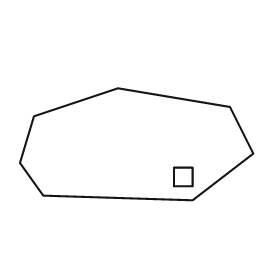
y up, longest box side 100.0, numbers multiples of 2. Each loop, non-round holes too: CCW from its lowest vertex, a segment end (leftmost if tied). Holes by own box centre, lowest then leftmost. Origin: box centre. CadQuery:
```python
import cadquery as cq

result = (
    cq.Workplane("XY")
    .moveTo(24.0, -24.0)
    .lineTo(50.0, -4.0)
    .lineTo(40.0, 16.0)
    .lineTo(-8.0, 24.0)
    .lineTo(-44.0, 12.0)
    .lineTo(-50.0, -8.0)
    .lineTo(-40.0, -22.0)
    .close()
    .moveTo(16.0, -18.0)
    .lineTo(24.0, -18.0)
    .lineTo(24.0, -10.0)
    .lineTo(16.0, -10.0)
    .close()
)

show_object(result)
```